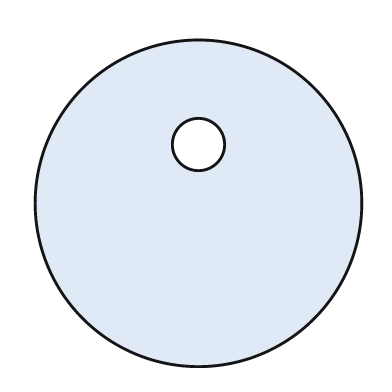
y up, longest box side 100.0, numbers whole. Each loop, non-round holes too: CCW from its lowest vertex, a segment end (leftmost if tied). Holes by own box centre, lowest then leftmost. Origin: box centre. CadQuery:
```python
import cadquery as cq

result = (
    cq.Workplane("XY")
    .moveTo(0.0, 0.0)
    .circle(50.0)
    .moveTo(0.0, 18.0)
    .circle(8.0)
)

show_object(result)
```